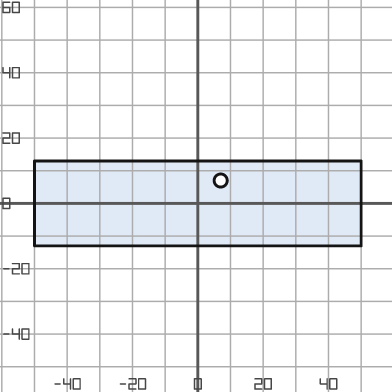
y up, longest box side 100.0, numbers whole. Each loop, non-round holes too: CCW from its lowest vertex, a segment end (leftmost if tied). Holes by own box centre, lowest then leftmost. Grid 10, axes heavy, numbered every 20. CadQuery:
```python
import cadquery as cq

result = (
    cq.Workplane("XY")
    .moveTo(-50.0, -13.0)
    .lineTo(50.0, -13.0)
    .lineTo(50.0, 13.0)
    .lineTo(-50.0, 13.0)
    .close()
    .moveTo(7.0, 7.0)
    .circle(2.0)
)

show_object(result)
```